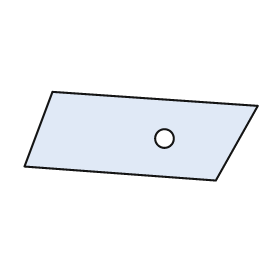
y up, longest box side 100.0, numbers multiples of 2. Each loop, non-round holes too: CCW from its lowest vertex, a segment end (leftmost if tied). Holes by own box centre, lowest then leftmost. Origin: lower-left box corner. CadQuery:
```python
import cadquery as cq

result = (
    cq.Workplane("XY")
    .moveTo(82.0, 0.0)
    .lineTo(100.0, 32.0)
    .lineTo(12.0, 38.0)
    .lineTo(0.0, 6.0)
    .close()
    .moveTo(60.0, 18.0)
    .circle(4.0)
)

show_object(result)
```